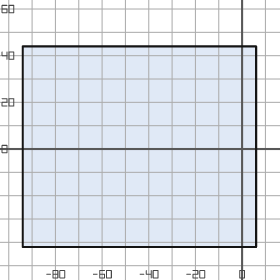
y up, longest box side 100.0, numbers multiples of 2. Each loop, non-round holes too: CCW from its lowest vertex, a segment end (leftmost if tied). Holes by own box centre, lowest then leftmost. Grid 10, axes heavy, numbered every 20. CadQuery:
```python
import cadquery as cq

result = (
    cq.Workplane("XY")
    .moveTo(-94.0, -42.0)
    .lineTo(6.0, -42.0)
    .lineTo(6.0, 44.0)
    .lineTo(-94.0, 44.0)
    .close()
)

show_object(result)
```